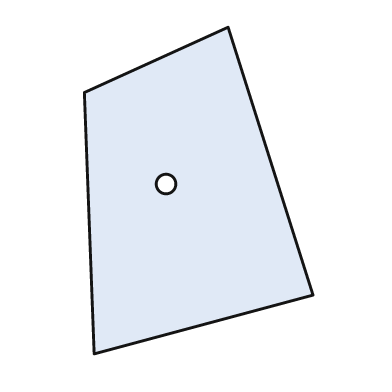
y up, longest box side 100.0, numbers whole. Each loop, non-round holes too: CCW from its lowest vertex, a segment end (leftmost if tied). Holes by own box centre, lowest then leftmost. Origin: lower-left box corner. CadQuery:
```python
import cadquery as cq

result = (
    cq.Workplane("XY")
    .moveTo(3.0, 0.0)
    .lineTo(70.0, 18.0)
    .lineTo(44.0, 100.0)
    .lineTo(0.0, 80.0)
    .close()
    .moveTo(25.0, 52.0)
    .circle(3.0)
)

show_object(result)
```